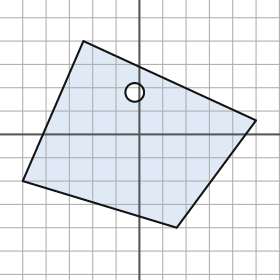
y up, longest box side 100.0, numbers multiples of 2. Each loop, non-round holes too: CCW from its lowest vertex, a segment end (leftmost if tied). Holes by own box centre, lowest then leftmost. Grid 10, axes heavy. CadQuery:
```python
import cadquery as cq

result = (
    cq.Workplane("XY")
    .moveTo(16.0, -40.0)
    .lineTo(50.0, 6.0)
    .lineTo(-24.0, 40.0)
    .lineTo(-50.0, -20.0)
    .close()
    .moveTo(-2.0, 18.0)
    .circle(4.0)
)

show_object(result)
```